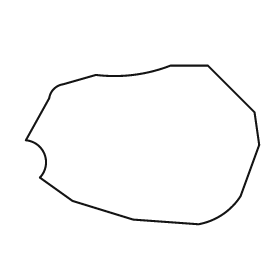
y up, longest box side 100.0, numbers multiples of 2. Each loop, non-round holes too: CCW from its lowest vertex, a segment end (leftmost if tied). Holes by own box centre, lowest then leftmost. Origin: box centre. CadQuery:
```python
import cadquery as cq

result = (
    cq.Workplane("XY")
    .moveTo(24.0, -34.0)
    .threePointArc((34.0, -30.0), (42.0, -22.0))
    .lineTo(50.0, 0.0)
    .lineTo(48.0, 14.0)
    .lineTo(28.0, 34.0)
    .lineTo(12.0, 34.0)
    .threePointArc((-4.0, 30.0), (-20.0, 30.0))
    .lineTo(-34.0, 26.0)
    .threePointArc((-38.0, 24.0), (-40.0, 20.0))
    .lineTo(-50.0, 2.0)
    .threePointArc((-42.0, -4.0), (-44.0, -14.0))
    .lineTo(-30.0, -24.0)
    .lineTo(-4.0, -32.0)
    .close()
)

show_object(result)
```